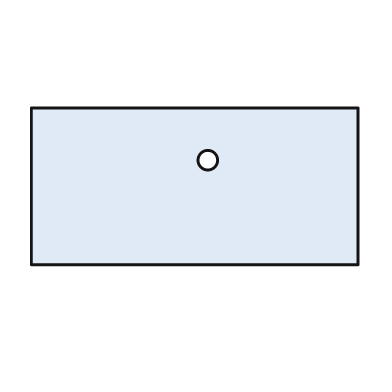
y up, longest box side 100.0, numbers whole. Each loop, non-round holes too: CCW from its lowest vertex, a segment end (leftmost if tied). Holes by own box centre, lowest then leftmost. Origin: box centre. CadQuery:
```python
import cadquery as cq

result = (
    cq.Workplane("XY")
    .moveTo(-50.0, -24.0)
    .lineTo(50.0, -24.0)
    .lineTo(50.0, 24.0)
    .lineTo(-50.0, 24.0)
    .close()
    .moveTo(4.0, 8.0)
    .circle(3.0)
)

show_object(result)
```